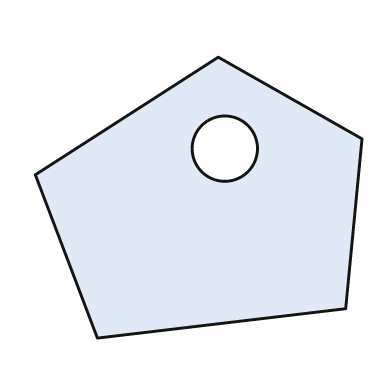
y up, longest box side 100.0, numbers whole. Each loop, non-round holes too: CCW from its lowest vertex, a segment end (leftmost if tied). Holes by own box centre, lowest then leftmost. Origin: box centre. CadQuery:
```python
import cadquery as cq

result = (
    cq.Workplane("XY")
    .moveTo(-31.0, -43.0)
    .lineTo(45.0, -34.0)
    .lineTo(50.0, 18.0)
    .lineTo(6.0, 43.0)
    .lineTo(-50.0, 7.0)
    .close()
    .moveTo(8.0, 15.0)
    .circle(10.0)
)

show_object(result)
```